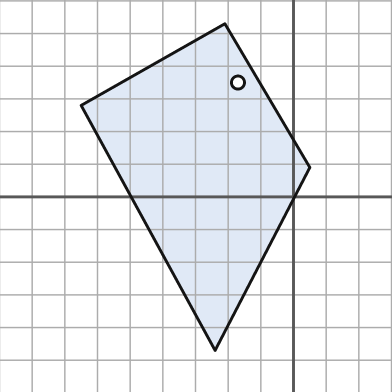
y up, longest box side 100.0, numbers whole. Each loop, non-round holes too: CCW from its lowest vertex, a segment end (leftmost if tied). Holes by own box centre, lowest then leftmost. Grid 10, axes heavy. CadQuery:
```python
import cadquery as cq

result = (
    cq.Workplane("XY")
    .moveTo(-24.0, -47.0)
    .lineTo(5.0, 9.0)
    .lineTo(-21.0, 53.0)
    .lineTo(-65.0, 28.0)
    .close()
    .moveTo(-17.0, 35.0)
    .circle(2.0)
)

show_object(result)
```